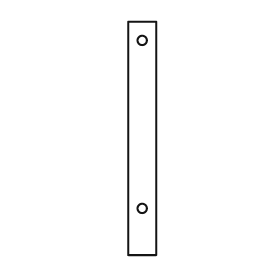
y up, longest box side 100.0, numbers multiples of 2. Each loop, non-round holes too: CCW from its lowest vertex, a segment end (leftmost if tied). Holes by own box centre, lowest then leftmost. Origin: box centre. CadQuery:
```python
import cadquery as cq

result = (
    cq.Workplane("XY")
    .moveTo(-6.0, -50.0)
    .lineTo(6.0, -50.0)
    .lineTo(6.0, 50.0)
    .lineTo(-6.0, 50.0)
    .close()
    .moveTo(0.0, -30.0)
    .circle(2.0)
    .moveTo(0.0, 42.0)
    .circle(2.0)
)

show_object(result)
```